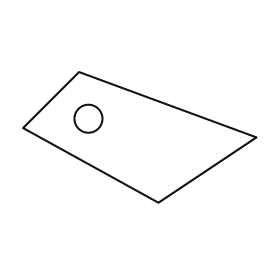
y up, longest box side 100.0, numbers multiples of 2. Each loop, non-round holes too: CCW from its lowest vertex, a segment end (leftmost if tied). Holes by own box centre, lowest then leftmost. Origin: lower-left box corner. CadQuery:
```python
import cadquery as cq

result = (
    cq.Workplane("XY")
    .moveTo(58.0, 0.0)
    .lineTo(100.0, 28.0)
    .lineTo(24.0, 56.0)
    .lineTo(0.0, 32.0)
    .close()
    .moveTo(28.0, 36.0)
    .circle(6.0)
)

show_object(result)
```